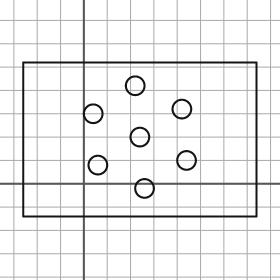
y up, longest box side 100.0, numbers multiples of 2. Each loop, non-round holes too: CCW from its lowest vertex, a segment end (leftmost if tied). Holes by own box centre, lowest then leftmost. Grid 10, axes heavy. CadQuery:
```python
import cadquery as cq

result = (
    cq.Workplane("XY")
    .moveTo(-26.0, -14.0)
    .lineTo(74.0, -14.0)
    .lineTo(74.0, 52.0)
    .lineTo(-26.0, 52.0)
    .close()
    .moveTo(26.0, -2.0)
    .circle(4.0)
    .moveTo(6.0, 8.0)
    .circle(4.0)
    .moveTo(44.0, 10.0)
    .circle(4.0)
    .moveTo(24.0, 20.0)
    .circle(4.0)
    .moveTo(4.0, 30.0)
    .circle(4.0)
    .moveTo(42.0, 32.0)
    .circle(4.0)
    .moveTo(22.0, 42.0)
    .circle(4.0)
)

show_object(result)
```